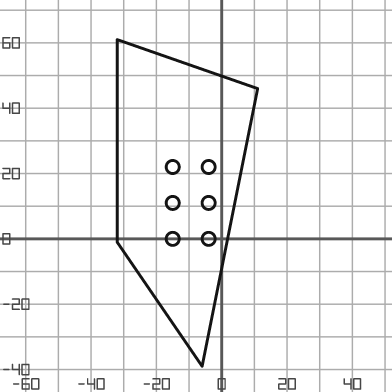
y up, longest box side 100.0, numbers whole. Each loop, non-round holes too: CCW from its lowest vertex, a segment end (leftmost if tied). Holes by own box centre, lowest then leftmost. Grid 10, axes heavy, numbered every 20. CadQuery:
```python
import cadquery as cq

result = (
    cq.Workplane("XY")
    .moveTo(-6.0, -39.0)
    .lineTo(11.0, 46.0)
    .lineTo(-32.0, 61.0)
    .lineTo(-32.0, -1.0)
    .close()
    .moveTo(-15.0, 0.0)
    .circle(2.0)
    .moveTo(-4.0, 0.0)
    .circle(2.0)
    .moveTo(-15.0, 11.0)
    .circle(2.0)
    .moveTo(-4.0, 11.0)
    .circle(2.0)
    .moveTo(-15.0, 22.0)
    .circle(2.0)
    .moveTo(-4.0, 22.0)
    .circle(2.0)
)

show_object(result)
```